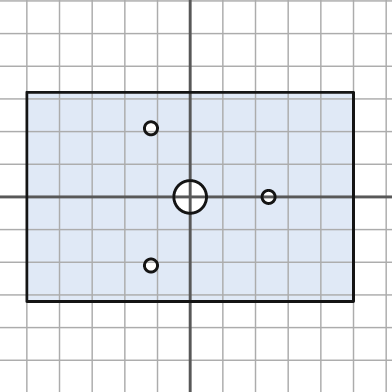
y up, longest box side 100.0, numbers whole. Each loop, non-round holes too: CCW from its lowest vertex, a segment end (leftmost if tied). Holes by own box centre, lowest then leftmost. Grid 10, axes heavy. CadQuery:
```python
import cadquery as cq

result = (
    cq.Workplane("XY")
    .moveTo(-50.0, -32.0)
    .lineTo(50.0, -32.0)
    .lineTo(50.0, 32.0)
    .lineTo(-50.0, 32.0)
    .close()
    .moveTo(-12.0, -21.0)
    .circle(2.0)
    .moveTo(0.0, 0.0)
    .circle(5.0)
    .moveTo(24.0, 0.0)
    .circle(2.0)
    .moveTo(-12.0, 21.0)
    .circle(2.0)
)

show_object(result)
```